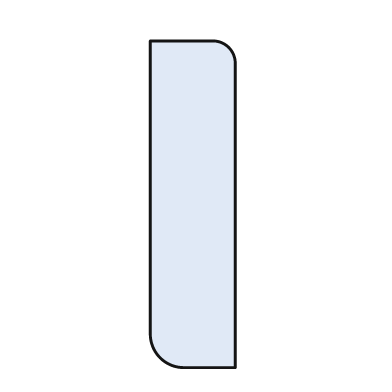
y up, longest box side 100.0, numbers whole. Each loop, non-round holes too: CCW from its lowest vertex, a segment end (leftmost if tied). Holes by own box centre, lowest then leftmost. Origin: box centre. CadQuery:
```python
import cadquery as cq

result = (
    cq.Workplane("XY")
    .moveTo(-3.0, -50.0)
    .lineTo(13.0, -50.0)
    .lineTo(13.0, 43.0)
    .threePointArc((11.0, 48.0), (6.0, 50.0))
    .lineTo(-13.0, 50.0)
    .lineTo(-13.0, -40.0)
    .threePointArc((-10.0, -47.0), (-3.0, -50.0))
    .close()
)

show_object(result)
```